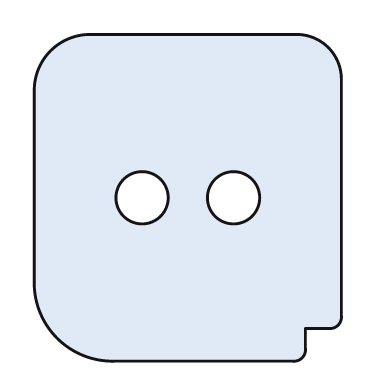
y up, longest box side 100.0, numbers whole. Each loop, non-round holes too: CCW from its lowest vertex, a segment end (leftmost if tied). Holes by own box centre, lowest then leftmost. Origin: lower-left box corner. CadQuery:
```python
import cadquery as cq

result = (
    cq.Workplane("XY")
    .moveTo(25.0, 0.0)
    .lineTo(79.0, 0.0)
    .threePointArc((82.0, 1.0), (83.0, 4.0))
    .lineTo(83.0, 10.0)
    .lineTo(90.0, 10.0)
    .threePointArc((93.0, 11.0), (94.0, 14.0))
    .lineTo(94.0, 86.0)
    .threePointArc((90.0, 96.0), (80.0, 100.0))
    .lineTo(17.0, 100.0)
    .threePointArc((5.0, 95.0), (0.0, 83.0))
    .lineTo(0.0, 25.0)
    .threePointArc((7.0, 7.0), (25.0, 0.0))
    .close()
    .moveTo(33.0, 50.0)
    .circle(8.0)
    .moveTo(61.0, 50.0)
    .circle(8.0)
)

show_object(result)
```